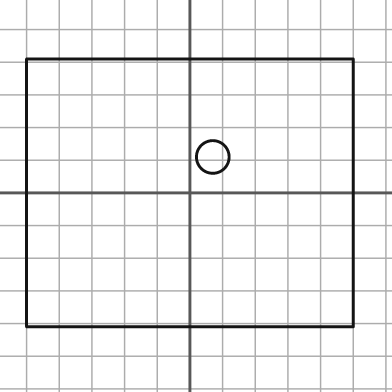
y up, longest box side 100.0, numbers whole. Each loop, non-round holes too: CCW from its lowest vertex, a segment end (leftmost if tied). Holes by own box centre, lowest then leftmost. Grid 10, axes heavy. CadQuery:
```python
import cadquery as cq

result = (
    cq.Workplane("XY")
    .moveTo(-50.0, -41.0)
    .lineTo(50.0, -41.0)
    .lineTo(50.0, 41.0)
    .lineTo(-50.0, 41.0)
    .close()
    .moveTo(7.0, 11.0)
    .circle(5.0)
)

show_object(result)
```